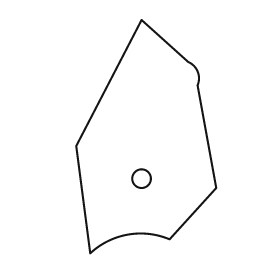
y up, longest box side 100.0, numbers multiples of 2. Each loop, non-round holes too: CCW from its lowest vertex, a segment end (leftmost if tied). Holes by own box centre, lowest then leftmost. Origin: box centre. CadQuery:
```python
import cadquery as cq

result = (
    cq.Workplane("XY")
    .moveTo(-24.0, -50.0)
    .threePointArc((-8.0, -42.0), (10.0, -44.0))
    .lineTo(30.0, -22.0)
    .lineTo(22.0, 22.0)
    .threePointArc((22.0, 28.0), (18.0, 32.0))
    .lineTo(-2.0, 50.0)
    .lineTo(-30.0, -4.0)
    .close()
    .moveTo(-2.0, -18.0)
    .circle(4.0)
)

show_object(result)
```